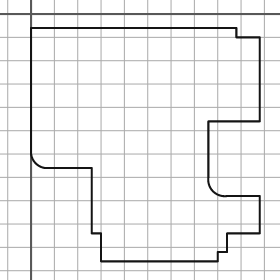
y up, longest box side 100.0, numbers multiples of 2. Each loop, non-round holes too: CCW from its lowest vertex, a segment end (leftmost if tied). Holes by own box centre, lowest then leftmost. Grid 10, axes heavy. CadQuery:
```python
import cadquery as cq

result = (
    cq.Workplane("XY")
    .moveTo(30.0, -106.0)
    .lineTo(80.0, -106.0)
    .lineTo(80.0, -102.0)
    .lineTo(84.0, -102.0)
    .lineTo(84.0, -94.0)
    .lineTo(98.0, -94.0)
    .lineTo(98.0, -78.0)
    .lineTo(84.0, -78.0)
    .threePointArc((78.0, -76.0), (76.0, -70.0))
    .lineTo(76.0, -46.0)
    .lineTo(98.0, -46.0)
    .lineTo(98.0, -10.0)
    .lineTo(88.0, -10.0)
    .lineTo(88.0, -6.0)
    .lineTo(0.0, -6.0)
    .lineTo(0.0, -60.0)
    .threePointArc((2.0, -64.0), (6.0, -66.0))
    .lineTo(26.0, -66.0)
    .lineTo(26.0, -94.0)
    .lineTo(30.0, -94.0)
    .close()
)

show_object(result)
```